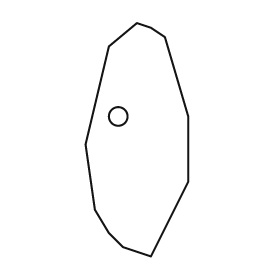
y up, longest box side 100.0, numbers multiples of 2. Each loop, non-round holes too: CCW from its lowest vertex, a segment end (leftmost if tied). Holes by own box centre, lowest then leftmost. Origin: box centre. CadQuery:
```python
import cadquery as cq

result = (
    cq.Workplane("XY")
    .moveTo(6.0, -50.0)
    .lineTo(22.0, -18.0)
    .lineTo(22.0, 10.0)
    .lineTo(12.0, 44.0)
    .lineTo(6.0, 48.0)
    .lineTo(0.0, 50.0)
    .lineTo(-12.0, 40.0)
    .lineTo(-22.0, -2.0)
    .lineTo(-18.0, -30.0)
    .lineTo(-12.0, -40.0)
    .lineTo(-6.0, -46.0)
    .close()
    .moveTo(-8.0, 10.0)
    .circle(4.0)
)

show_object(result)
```